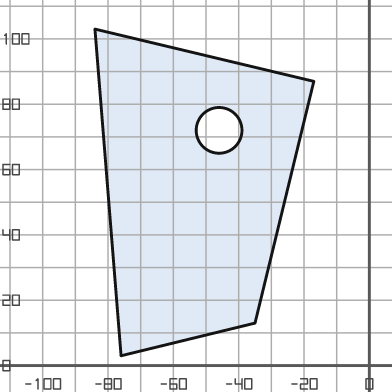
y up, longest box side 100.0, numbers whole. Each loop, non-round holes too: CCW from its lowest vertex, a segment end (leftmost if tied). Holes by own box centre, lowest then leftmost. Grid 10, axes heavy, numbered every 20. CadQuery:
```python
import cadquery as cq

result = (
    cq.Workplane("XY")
    .moveTo(-76.0, 3.0)
    .lineTo(-35.0, 13.0)
    .lineTo(-17.0, 87.0)
    .lineTo(-84.0, 103.0)
    .close()
    .moveTo(-46.0, 72.0)
    .circle(7.0)
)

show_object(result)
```